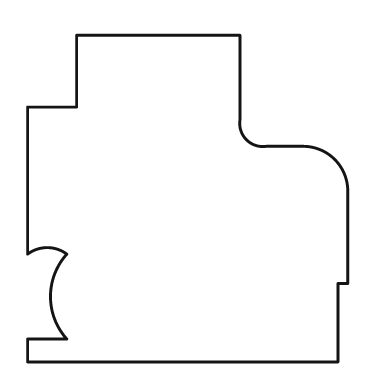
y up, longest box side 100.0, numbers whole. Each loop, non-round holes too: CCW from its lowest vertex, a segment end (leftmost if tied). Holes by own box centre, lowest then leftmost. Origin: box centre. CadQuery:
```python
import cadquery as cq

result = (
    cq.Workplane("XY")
    .moveTo(-49.0, -50.0)
    .lineTo(46.0, -50.0)
    .lineTo(46.0, -26.0)
    .lineTo(49.0, -26.0)
    .lineTo(49.0, 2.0)
    .threePointArc((45.0, 12.0), (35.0, 16.0))
    .lineTo(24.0, 16.0)
    .threePointArc((18.0, 18.0), (16.0, 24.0))
    .lineTo(16.0, 50.0)
    .lineTo(-34.0, 50.0)
    .lineTo(-34.0, 28.0)
    .lineTo(-49.0, 28.0)
    .lineTo(-49.0, -17.0)
    .threePointArc((-43.0, -15.0), (-37.0, -17.0))
    .threePointArc((-42.0, -30.0), (-37.0, -43.0))
    .lineTo(-49.0, -43.0)
    .close()
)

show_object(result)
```